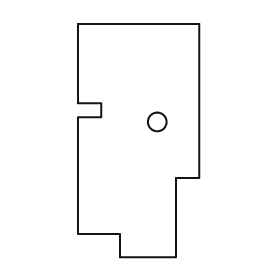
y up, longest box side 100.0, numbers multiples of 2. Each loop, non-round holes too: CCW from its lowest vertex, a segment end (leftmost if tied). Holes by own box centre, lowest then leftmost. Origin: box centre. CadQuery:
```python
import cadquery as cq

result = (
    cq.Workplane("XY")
    .moveTo(-8.0, -50.0)
    .lineTo(16.0, -50.0)
    .lineTo(16.0, -16.0)
    .lineTo(26.0, -16.0)
    .lineTo(26.0, 50.0)
    .lineTo(-26.0, 50.0)
    .lineTo(-26.0, 16.0)
    .lineTo(-16.0, 16.0)
    .lineTo(-16.0, 10.0)
    .lineTo(-26.0, 10.0)
    .lineTo(-26.0, -40.0)
    .lineTo(-8.0, -40.0)
    .close()
    .moveTo(8.0, 8.0)
    .circle(4.0)
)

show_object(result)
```